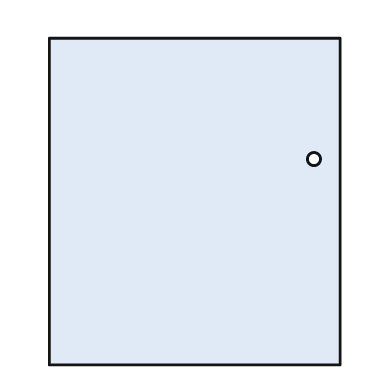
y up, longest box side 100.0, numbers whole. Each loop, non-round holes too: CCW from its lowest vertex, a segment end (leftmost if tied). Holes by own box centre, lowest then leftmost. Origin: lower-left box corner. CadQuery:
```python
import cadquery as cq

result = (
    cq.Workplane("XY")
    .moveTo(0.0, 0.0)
    .lineTo(89.0, 0.0)
    .lineTo(89.0, 100.0)
    .lineTo(0.0, 100.0)
    .close()
    .moveTo(81.0, 63.0)
    .circle(2.0)
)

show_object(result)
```